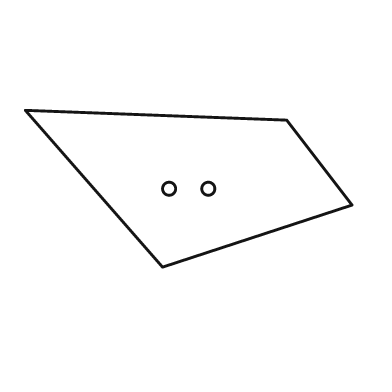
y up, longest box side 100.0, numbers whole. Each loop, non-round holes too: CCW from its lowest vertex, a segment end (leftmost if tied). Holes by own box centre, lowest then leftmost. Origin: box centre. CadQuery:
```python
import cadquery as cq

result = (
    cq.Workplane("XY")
    .moveTo(-8.0, -24.0)
    .lineTo(50.0, -5.0)
    .lineTo(30.0, 21.0)
    .lineTo(-50.0, 24.0)
    .close()
    .moveTo(-6.0, 0.0)
    .circle(2.0)
    .moveTo(6.0, 0.0)
    .circle(2.0)
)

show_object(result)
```